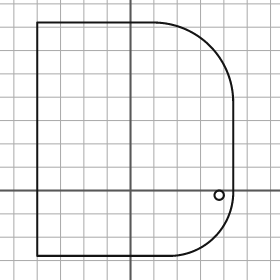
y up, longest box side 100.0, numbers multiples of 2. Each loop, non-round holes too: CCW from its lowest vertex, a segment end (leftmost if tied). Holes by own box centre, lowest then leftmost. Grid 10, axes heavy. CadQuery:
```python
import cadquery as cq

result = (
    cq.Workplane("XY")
    .moveTo(-40.0, -28.0)
    .lineTo(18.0, -28.0)
    .threePointArc((36.0, -20.0), (44.0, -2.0))
    .lineTo(44.0, 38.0)
    .threePointArc((34.0, 62.0), (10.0, 72.0))
    .lineTo(-40.0, 72.0)
    .close()
    .moveTo(38.0, -2.0)
    .circle(2.0)
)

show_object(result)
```